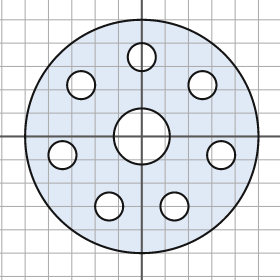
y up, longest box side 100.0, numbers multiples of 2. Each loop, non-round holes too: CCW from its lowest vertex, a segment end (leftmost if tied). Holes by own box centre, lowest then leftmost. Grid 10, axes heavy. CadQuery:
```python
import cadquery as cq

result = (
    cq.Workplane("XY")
    .moveTo(0.0, 0.0)
    .circle(50.0)
    .moveTo(-14.0, -30.0)
    .circle(6.0)
    .moveTo(14.0, -30.0)
    .circle(6.0)
    .moveTo(-34.0, -8.0)
    .circle(6.0)
    .moveTo(34.0, -8.0)
    .circle(6.0)
    .moveTo(0.0, 0.0)
    .circle(12.0)
    .moveTo(-26.0, 22.0)
    .circle(6.0)
    .moveTo(26.0, 22.0)
    .circle(6.0)
    .moveTo(0.0, 34.0)
    .circle(6.0)
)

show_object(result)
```